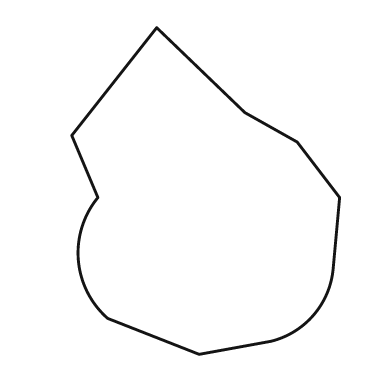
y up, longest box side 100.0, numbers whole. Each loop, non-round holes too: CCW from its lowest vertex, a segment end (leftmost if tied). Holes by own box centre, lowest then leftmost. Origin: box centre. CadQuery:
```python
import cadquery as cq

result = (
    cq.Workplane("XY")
    .moveTo(-2.0, -50.0)
    .lineTo(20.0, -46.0)
    .threePointArc((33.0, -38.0), (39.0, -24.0))
    .lineTo(41.0, -2.0)
    .lineTo(28.0, 15.0)
    .lineTo(12.0, 24.0)
    .lineTo(-15.0, 50.0)
    .lineTo(-41.0, 17.0)
    .lineTo(-33.0, -2.0)
    .threePointArc((-39.0, -21.0), (-30.0, -39.0))
    .close()
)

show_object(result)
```